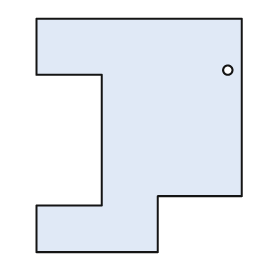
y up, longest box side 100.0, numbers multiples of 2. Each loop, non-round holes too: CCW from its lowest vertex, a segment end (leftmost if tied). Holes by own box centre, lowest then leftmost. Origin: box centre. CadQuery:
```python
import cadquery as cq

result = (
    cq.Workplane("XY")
    .moveTo(-44.0, -50.0)
    .lineTo(8.0, -50.0)
    .lineTo(8.0, -26.0)
    .lineTo(44.0, -26.0)
    .lineTo(44.0, 50.0)
    .lineTo(-44.0, 50.0)
    .lineTo(-44.0, 26.0)
    .lineTo(-16.0, 26.0)
    .lineTo(-16.0, -30.0)
    .lineTo(-44.0, -30.0)
    .close()
    .moveTo(38.0, 28.0)
    .circle(2.0)
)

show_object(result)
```